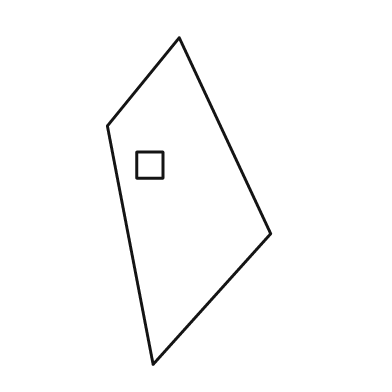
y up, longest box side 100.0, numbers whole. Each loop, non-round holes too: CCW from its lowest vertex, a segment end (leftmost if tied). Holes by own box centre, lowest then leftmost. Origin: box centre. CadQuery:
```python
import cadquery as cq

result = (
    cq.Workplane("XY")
    .moveTo(-11.0, -50.0)
    .lineTo(25.0, -10.0)
    .lineTo(-3.0, 50.0)
    .lineTo(-25.0, 23.0)
    .close()
    .moveTo(-16.0, 7.0)
    .lineTo(-8.0, 7.0)
    .lineTo(-8.0, 15.0)
    .lineTo(-16.0, 15.0)
    .close()
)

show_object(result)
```